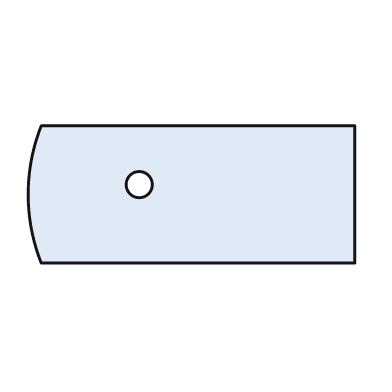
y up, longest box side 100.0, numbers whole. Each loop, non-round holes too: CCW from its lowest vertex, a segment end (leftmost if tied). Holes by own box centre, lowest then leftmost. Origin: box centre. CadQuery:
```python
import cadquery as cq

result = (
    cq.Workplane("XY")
    .moveTo(-46.0, -21.0)
    .lineTo(50.0, -21.0)
    .lineTo(50.0, 21.0)
    .lineTo(-46.0, 21.0)
    .threePointArc((-50.0, 0.0), (-46.0, -21.0))
    .close()
    .moveTo(-16.0, 3.0)
    .circle(4.0)
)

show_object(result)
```